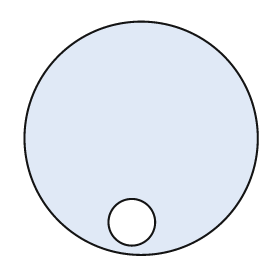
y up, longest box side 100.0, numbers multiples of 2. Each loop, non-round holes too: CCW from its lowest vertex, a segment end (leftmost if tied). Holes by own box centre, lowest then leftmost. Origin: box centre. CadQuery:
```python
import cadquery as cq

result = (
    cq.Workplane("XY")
    .moveTo(0.0, 0.0)
    .circle(50.0)
    .moveTo(-4.0, -36.0)
    .circle(10.0)
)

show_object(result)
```